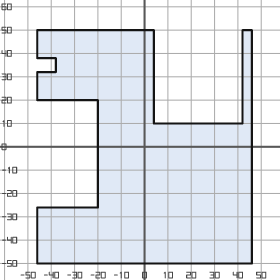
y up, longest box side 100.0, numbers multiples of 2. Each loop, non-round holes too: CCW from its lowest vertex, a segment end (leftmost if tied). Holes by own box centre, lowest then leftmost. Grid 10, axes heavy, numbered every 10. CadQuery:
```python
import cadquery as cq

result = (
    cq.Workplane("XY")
    .moveTo(-46.0, -50.0)
    .lineTo(46.0, -50.0)
    .lineTo(46.0, 50.0)
    .lineTo(42.0, 50.0)
    .lineTo(42.0, 10.0)
    .lineTo(4.0, 10.0)
    .lineTo(4.0, 50.0)
    .lineTo(-46.0, 50.0)
    .lineTo(-46.0, 38.0)
    .lineTo(-38.0, 38.0)
    .lineTo(-38.0, 32.0)
    .lineTo(-46.0, 32.0)
    .lineTo(-46.0, 20.0)
    .lineTo(-20.0, 20.0)
    .lineTo(-20.0, -26.0)
    .lineTo(-46.0, -26.0)
    .close()
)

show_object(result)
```